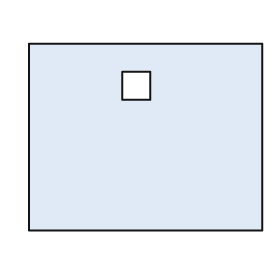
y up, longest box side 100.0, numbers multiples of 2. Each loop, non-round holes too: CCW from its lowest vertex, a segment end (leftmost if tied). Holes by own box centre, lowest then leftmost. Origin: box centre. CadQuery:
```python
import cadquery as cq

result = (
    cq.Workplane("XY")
    .moveTo(-50.0, -40.0)
    .lineTo(50.0, -40.0)
    .lineTo(50.0, 40.0)
    .lineTo(-50.0, 40.0)
    .close()
    .moveTo(-10.0, 16.0)
    .lineTo(2.0, 16.0)
    .lineTo(2.0, 28.0)
    .lineTo(-10.0, 28.0)
    .close()
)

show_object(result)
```